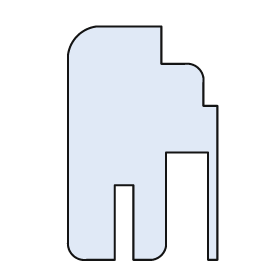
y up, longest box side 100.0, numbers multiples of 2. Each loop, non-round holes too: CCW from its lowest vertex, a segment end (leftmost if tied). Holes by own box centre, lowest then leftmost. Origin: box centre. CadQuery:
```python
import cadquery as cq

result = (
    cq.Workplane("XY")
    .moveTo(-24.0, -50.0)
    .lineTo(-12.0, -50.0)
    .lineTo(-12.0, -18.0)
    .lineTo(-4.0, -18.0)
    .lineTo(-4.0, -50.0)
    .lineTo(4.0, -50.0)
    .threePointArc((8.0, -48.0), (10.0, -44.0))
    .lineTo(10.0, -4.0)
    .lineTo(28.0, -4.0)
    .lineTo(28.0, -50.0)
    .lineTo(32.0, -50.0)
    .lineTo(32.0, 16.0)
    .lineTo(26.0, 16.0)
    .lineTo(26.0, 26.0)
    .threePointArc((24.0, 32.0), (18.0, 34.0))
    .lineTo(8.0, 34.0)
    .lineTo(8.0, 50.0)
    .lineTo(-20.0, 50.0)
    .threePointArc((-28.0, 46.0), (-32.0, 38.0))
    .lineTo(-32.0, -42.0)
    .threePointArc((-30.0, -48.0), (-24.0, -50.0))
    .close()
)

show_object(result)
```